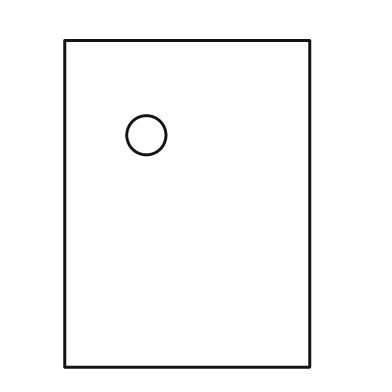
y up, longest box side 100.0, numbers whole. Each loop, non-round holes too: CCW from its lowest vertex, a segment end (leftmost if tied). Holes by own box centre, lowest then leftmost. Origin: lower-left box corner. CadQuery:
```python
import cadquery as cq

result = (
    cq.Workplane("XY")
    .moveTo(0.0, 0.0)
    .lineTo(75.0, 0.0)
    .lineTo(75.0, 100.0)
    .lineTo(0.0, 100.0)
    .close()
    .moveTo(25.0, 71.0)
    .circle(6.0)
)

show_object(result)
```